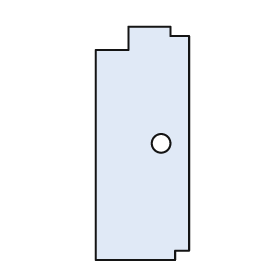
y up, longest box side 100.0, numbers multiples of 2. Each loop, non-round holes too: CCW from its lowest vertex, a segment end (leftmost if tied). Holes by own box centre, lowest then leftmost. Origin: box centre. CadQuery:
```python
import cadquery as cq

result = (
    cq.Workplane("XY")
    .moveTo(-20.0, -50.0)
    .lineTo(14.0, -50.0)
    .lineTo(14.0, -46.0)
    .lineTo(20.0, -46.0)
    .lineTo(20.0, 46.0)
    .lineTo(12.0, 46.0)
    .lineTo(12.0, 50.0)
    .lineTo(-6.0, 50.0)
    .lineTo(-6.0, 40.0)
    .lineTo(-20.0, 40.0)
    .close()
    .moveTo(8.0, 0.0)
    .circle(4.0)
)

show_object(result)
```